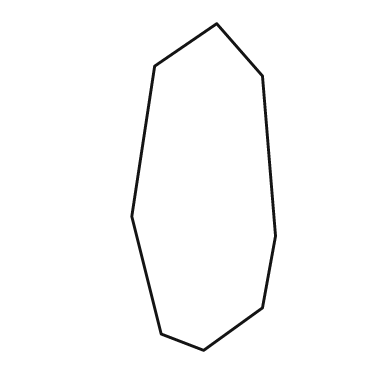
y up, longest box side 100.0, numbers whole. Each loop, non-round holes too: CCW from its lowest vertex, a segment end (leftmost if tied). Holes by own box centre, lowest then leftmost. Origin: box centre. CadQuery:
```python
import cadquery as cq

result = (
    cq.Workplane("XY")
    .moveTo(0.0, -50.0)
    .lineTo(18.0, -37.0)
    .lineTo(22.0, -15.0)
    .lineTo(18.0, 34.0)
    .lineTo(4.0, 50.0)
    .lineTo(-15.0, 37.0)
    .lineTo(-22.0, -9.0)
    .lineTo(-13.0, -45.0)
    .close()
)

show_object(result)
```